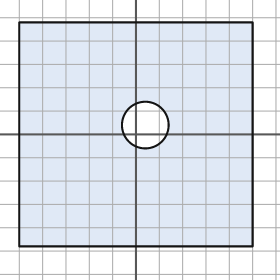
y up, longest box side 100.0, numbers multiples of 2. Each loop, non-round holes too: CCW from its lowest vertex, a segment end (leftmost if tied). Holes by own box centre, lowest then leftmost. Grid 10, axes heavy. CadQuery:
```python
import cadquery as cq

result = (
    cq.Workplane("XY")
    .moveTo(-50.0, -48.0)
    .lineTo(50.0, -48.0)
    .lineTo(50.0, 48.0)
    .lineTo(-50.0, 48.0)
    .close()
    .moveTo(4.0, 4.0)
    .circle(10.0)
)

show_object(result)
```